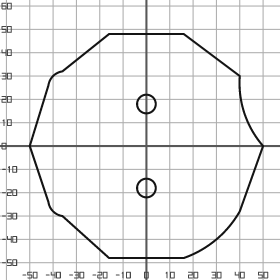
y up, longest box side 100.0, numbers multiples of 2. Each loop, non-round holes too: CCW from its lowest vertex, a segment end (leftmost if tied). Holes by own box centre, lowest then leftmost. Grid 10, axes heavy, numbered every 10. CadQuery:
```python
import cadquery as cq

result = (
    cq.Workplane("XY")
    .moveTo(-16.0, -48.0)
    .lineTo(16.0, -48.0)
    .threePointArc((30.0, -40.0), (40.0, -28.0))
    .lineTo(50.0, 0.0)
    .threePointArc((42.0, 14.0), (40.0, 30.0))
    .lineTo(16.0, 48.0)
    .lineTo(-16.0, 48.0)
    .lineTo(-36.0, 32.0)
    .threePointArc((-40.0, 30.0), (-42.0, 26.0))
    .lineTo(-50.0, 0.0)
    .lineTo(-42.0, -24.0)
    .threePointArc((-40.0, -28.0), (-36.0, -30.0))
    .close()
    .moveTo(0.0, -18.0)
    .circle(4.0)
    .moveTo(0.0, 18.0)
    .circle(4.0)
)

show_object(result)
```